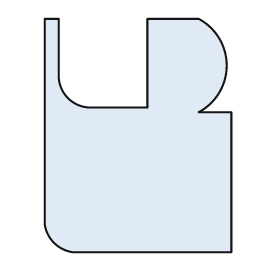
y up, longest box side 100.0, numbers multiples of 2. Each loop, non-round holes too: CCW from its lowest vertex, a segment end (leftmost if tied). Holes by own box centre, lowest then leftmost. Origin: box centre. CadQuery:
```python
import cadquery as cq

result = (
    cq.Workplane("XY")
    .moveTo(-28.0, -50.0)
    .lineTo(40.0, -50.0)
    .lineTo(40.0, 10.0)
    .lineTo(26.0, 10.0)
    .threePointArc((38.0, 30.0), (26.0, 50.0))
    .lineTo(4.0, 50.0)
    .lineTo(4.0, 12.0)
    .lineTo(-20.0, 12.0)
    .threePointArc((-30.0, 16.0), (-34.0, 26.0))
    .lineTo(-34.0, 50.0)
    .lineTo(-40.0, 50.0)
    .lineTo(-40.0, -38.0)
    .threePointArc((-36.0, -46.0), (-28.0, -50.0))
    .close()
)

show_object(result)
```